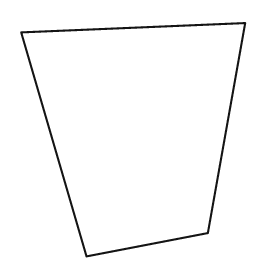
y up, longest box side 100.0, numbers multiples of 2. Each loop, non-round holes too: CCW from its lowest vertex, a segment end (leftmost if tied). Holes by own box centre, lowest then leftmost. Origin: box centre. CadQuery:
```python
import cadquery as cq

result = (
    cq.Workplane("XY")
    .moveTo(-20.0, -50.0)
    .lineTo(32.0, -40.0)
    .lineTo(48.0, 50.0)
    .lineTo(-48.0, 46.0)
    .close()
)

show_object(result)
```